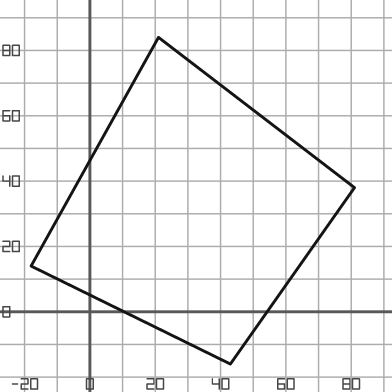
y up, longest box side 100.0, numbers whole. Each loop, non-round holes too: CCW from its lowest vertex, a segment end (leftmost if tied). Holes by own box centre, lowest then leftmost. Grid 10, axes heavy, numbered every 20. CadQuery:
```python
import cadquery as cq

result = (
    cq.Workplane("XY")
    .moveTo(43.0, -16.0)
    .lineTo(81.0, 38.0)
    .lineTo(21.0, 84.0)
    .lineTo(-18.0, 14.0)
    .close()
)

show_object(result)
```